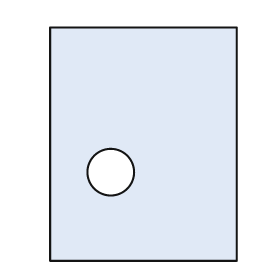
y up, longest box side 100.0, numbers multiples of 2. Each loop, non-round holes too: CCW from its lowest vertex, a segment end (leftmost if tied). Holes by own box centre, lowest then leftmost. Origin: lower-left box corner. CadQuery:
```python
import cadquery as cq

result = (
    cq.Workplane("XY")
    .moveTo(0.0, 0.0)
    .lineTo(80.0, 0.0)
    .lineTo(80.0, 100.0)
    .lineTo(0.0, 100.0)
    .close()
    .moveTo(26.0, 38.0)
    .circle(10.0)
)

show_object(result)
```